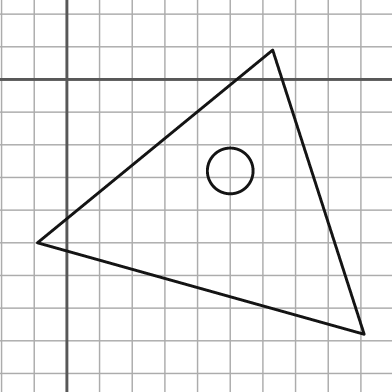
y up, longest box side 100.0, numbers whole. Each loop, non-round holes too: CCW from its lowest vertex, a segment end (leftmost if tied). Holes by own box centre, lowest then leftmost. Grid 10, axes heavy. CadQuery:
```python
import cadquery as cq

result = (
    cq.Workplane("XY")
    .moveTo(91.0, -78.0)
    .lineTo(63.0, 9.0)
    .lineTo(-9.0, -50.0)
    .close()
    .moveTo(50.0, -28.0)
    .circle(7.0)
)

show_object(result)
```